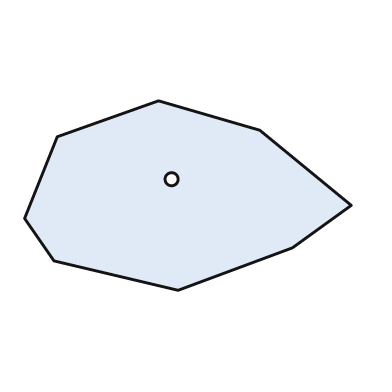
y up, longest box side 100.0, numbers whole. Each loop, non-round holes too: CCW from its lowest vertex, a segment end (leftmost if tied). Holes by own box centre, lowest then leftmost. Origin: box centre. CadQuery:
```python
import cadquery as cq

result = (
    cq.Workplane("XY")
    .moveTo(-3.0, -29.0)
    .lineTo(32.0, -16.0)
    .lineTo(50.0, -3.0)
    .lineTo(22.0, 20.0)
    .lineTo(-9.0, 29.0)
    .lineTo(-40.0, 18.0)
    .lineTo(-50.0, -7.0)
    .lineTo(-41.0, -20.0)
    .close()
    .moveTo(-5.0, 5.0)
    .circle(2.0)
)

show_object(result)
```